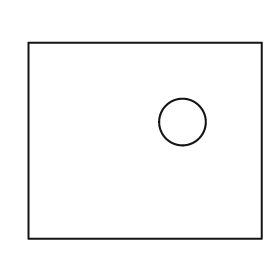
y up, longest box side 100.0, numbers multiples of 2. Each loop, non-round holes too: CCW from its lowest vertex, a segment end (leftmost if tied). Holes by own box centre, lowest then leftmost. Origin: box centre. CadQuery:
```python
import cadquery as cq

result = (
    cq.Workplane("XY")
    .moveTo(-50.0, -42.0)
    .lineTo(50.0, -42.0)
    .lineTo(50.0, 42.0)
    .lineTo(-50.0, 42.0)
    .close()
    .moveTo(16.0, 8.0)
    .circle(10.0)
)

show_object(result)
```